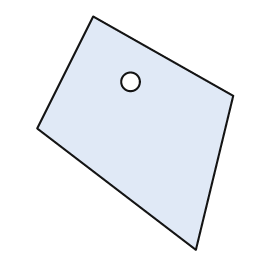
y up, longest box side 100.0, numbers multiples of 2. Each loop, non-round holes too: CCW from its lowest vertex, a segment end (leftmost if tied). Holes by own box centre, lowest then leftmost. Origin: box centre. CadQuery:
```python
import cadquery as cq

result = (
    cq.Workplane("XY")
    .moveTo(26.0, -50.0)
    .lineTo(42.0, 16.0)
    .lineTo(-18.0, 50.0)
    .lineTo(-42.0, 2.0)
    .close()
    .moveTo(-2.0, 22.0)
    .circle(4.0)
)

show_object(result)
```